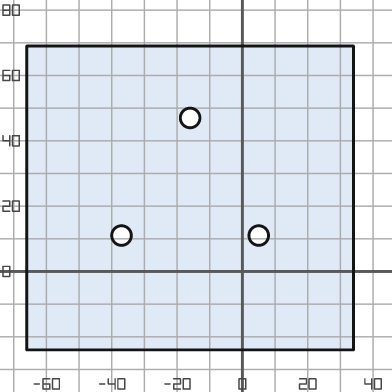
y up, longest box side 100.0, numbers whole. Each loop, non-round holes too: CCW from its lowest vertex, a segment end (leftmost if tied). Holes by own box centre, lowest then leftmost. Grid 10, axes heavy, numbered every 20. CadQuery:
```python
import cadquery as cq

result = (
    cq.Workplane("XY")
    .moveTo(-66.0, -24.0)
    .lineTo(34.0, -24.0)
    .lineTo(34.0, 69.0)
    .lineTo(-66.0, 69.0)
    .close()
    .moveTo(-37.0, 11.0)
    .circle(3.0)
    .moveTo(5.0, 11.0)
    .circle(3.0)
    .moveTo(-16.0, 47.0)
    .circle(3.0)
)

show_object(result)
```